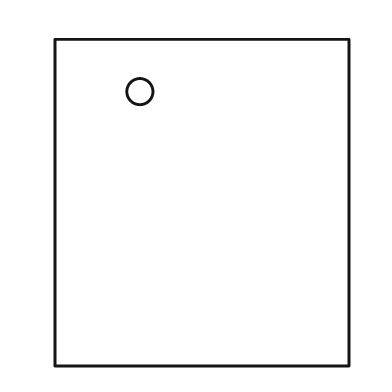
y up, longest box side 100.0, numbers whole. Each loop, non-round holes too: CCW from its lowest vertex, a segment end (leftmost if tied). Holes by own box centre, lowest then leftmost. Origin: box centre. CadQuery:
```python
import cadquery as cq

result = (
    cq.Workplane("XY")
    .moveTo(-45.0, -50.0)
    .lineTo(45.0, -50.0)
    .lineTo(45.0, 50.0)
    .lineTo(-45.0, 50.0)
    .close()
    .moveTo(-19.0, 34.0)
    .circle(4.0)
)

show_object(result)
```